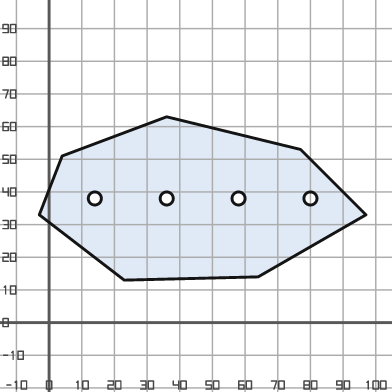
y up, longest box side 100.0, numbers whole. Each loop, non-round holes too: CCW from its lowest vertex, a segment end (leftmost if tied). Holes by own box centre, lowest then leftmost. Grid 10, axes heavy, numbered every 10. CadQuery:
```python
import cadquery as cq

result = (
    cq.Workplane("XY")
    .moveTo(23.0, 13.0)
    .lineTo(64.0, 14.0)
    .lineTo(97.0, 33.0)
    .lineTo(77.0, 53.0)
    .lineTo(36.0, 63.0)
    .lineTo(4.0, 51.0)
    .lineTo(-3.0, 33.0)
    .close()
    .moveTo(14.0, 38.0)
    .circle(2.0)
    .moveTo(36.0, 38.0)
    .circle(2.0)
    .moveTo(58.0, 38.0)
    .circle(2.0)
    .moveTo(80.0, 38.0)
    .circle(2.0)
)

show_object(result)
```